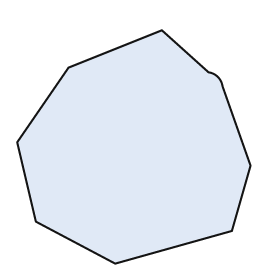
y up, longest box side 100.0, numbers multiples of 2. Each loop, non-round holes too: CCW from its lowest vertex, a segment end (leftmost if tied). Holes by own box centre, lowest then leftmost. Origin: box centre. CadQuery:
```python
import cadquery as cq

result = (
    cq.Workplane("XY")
    .moveTo(-8.0, -50.0)
    .lineTo(42.0, -36.0)
    .lineTo(50.0, -8.0)
    .lineTo(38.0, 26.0)
    .threePointArc((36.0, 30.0), (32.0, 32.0))
    .lineTo(12.0, 50.0)
    .lineTo(-28.0, 34.0)
    .lineTo(-50.0, 2.0)
    .lineTo(-42.0, -32.0)
    .close()
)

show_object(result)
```